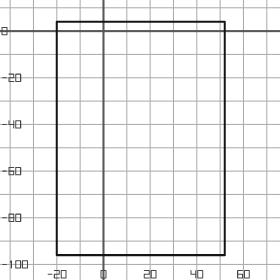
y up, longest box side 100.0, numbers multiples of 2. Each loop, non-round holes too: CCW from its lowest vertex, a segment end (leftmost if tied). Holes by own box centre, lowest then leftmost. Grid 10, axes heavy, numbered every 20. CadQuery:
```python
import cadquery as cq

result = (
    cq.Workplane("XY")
    .moveTo(-20.0, -96.0)
    .lineTo(52.0, -96.0)
    .lineTo(52.0, 4.0)
    .lineTo(-20.0, 4.0)
    .close()
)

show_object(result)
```